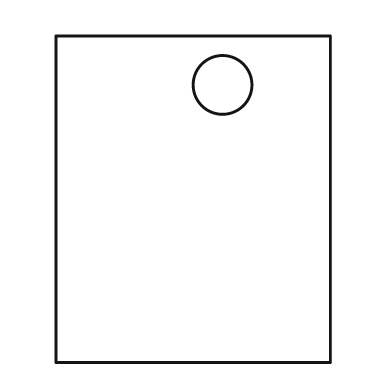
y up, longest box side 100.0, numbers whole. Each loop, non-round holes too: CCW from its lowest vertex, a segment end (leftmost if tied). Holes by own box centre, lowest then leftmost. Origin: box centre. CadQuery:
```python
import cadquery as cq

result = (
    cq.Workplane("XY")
    .moveTo(-42.0, -50.0)
    .lineTo(42.0, -50.0)
    .lineTo(42.0, 50.0)
    .lineTo(-42.0, 50.0)
    .close()
    .moveTo(9.0, 35.0)
    .circle(9.0)
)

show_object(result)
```